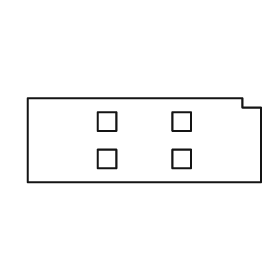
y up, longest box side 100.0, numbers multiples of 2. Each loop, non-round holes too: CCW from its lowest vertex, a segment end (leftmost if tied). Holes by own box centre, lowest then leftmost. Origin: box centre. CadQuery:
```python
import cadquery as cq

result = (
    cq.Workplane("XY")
    .moveTo(-50.0, -18.0)
    .lineTo(50.0, -18.0)
    .lineTo(50.0, 14.0)
    .lineTo(42.0, 14.0)
    .lineTo(42.0, 18.0)
    .lineTo(-50.0, 18.0)
    .close()
    .moveTo(-20.0, -12.0)
    .lineTo(-12.0, -12.0)
    .lineTo(-12.0, -4.0)
    .lineTo(-20.0, -4.0)
    .close()
    .moveTo(12.0, -12.0)
    .lineTo(20.0, -12.0)
    .lineTo(20.0, -4.0)
    .lineTo(12.0, -4.0)
    .close()
    .moveTo(-20.0, 4.0)
    .lineTo(-12.0, 4.0)
    .lineTo(-12.0, 12.0)
    .lineTo(-20.0, 12.0)
    .close()
    .moveTo(12.0, 4.0)
    .lineTo(20.0, 4.0)
    .lineTo(20.0, 12.0)
    .lineTo(12.0, 12.0)
    .close()
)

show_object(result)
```